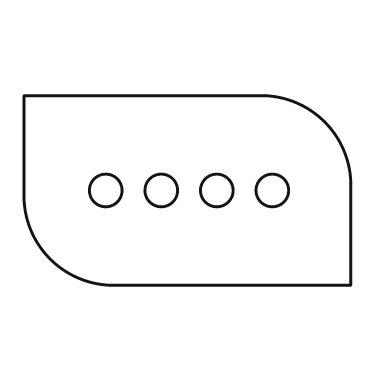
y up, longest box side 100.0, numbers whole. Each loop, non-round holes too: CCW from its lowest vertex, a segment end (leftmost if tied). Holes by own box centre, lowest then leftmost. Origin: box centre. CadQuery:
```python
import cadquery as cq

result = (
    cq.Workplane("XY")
    .moveTo(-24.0, -29.0)
    .lineTo(50.0, -29.0)
    .lineTo(50.0, 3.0)
    .threePointArc((42.0, 21.0), (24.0, 29.0))
    .lineTo(-50.0, 29.0)
    .lineTo(-50.0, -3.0)
    .threePointArc((-42.0, -21.0), (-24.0, -29.0))
    .close()
    .moveTo(-25.0, 0.0)
    .circle(5.0)
    .moveTo(-8.0, 0.0)
    .circle(5.0)
    .moveTo(9.0, 0.0)
    .circle(5.0)
    .moveTo(26.0, 0.0)
    .circle(5.0)
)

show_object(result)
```